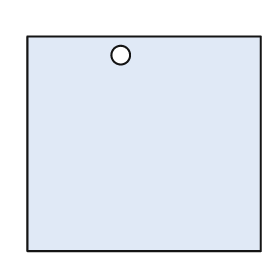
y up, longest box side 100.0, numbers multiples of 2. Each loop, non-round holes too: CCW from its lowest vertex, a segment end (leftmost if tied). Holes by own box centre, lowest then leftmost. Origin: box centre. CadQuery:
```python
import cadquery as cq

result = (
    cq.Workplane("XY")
    .moveTo(-50.0, -46.0)
    .lineTo(50.0, -46.0)
    .lineTo(50.0, 46.0)
    .lineTo(-50.0, 46.0)
    .close()
    .moveTo(-10.0, 38.0)
    .circle(4.0)
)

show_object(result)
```